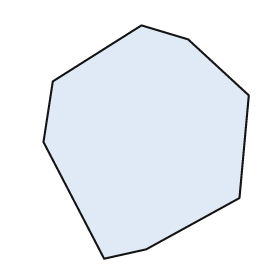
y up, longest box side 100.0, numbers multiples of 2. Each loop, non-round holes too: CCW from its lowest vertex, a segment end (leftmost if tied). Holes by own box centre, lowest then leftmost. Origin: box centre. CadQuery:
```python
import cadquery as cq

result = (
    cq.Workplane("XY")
    .moveTo(-18.0, -50.0)
    .lineTo(0.0, -46.0)
    .lineTo(40.0, -24.0)
    .lineTo(44.0, 20.0)
    .lineTo(18.0, 44.0)
    .lineTo(-2.0, 50.0)
    .lineTo(-40.0, 26.0)
    .lineTo(-44.0, 0.0)
    .close()
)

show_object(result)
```